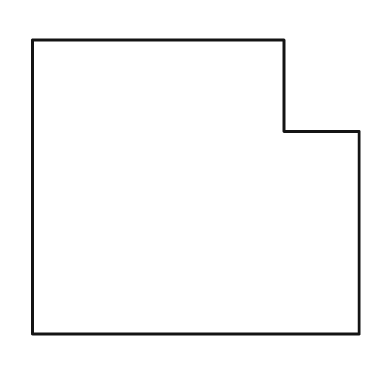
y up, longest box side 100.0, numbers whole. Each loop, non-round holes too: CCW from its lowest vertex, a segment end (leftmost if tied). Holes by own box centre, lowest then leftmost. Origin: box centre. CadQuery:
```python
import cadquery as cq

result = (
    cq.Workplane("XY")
    .moveTo(-50.0, -45.0)
    .lineTo(50.0, -45.0)
    .lineTo(50.0, 17.0)
    .lineTo(27.0, 17.0)
    .lineTo(27.0, 45.0)
    .lineTo(-50.0, 45.0)
    .close()
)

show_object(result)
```